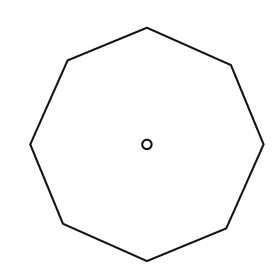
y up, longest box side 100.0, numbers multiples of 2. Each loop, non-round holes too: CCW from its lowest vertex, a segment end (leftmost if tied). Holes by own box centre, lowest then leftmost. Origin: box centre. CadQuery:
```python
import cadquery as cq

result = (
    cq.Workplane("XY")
    .moveTo(0.0, -50.0)
    .lineTo(34.0, -36.0)
    .lineTo(50.0, 0.0)
    .lineTo(36.0, 34.0)
    .lineTo(0.0, 50.0)
    .lineTo(-34.0, 36.0)
    .lineTo(-50.0, 0.0)
    .lineTo(-36.0, -34.0)
    .close()
    .moveTo(0.0, 0.0)
    .circle(2.0)
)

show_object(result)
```